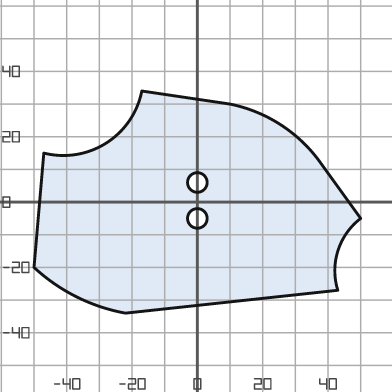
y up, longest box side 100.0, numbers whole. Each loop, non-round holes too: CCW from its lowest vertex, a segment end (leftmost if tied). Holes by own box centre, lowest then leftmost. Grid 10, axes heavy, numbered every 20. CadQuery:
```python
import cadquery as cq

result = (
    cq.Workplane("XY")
    .moveTo(-22.0, -34.0)
    .lineTo(43.0, -27.0)
    .threePointArc((43.0, -15.0), (50.0, -5.0))
    .lineTo(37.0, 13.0)
    .threePointArc((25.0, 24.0), (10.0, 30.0))
    .lineTo(-17.0, 34.0)
    .threePointArc((-28.0, 18.0), (-47.0, 15.0))
    .lineTo(-50.0, -20.0)
    .threePointArc((-37.0, -29.0), (-22.0, -34.0))
    .close()
    .moveTo(0.0, -5.0)
    .circle(3.0)
    .moveTo(0.0, 6.0)
    .circle(3.0)
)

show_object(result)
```